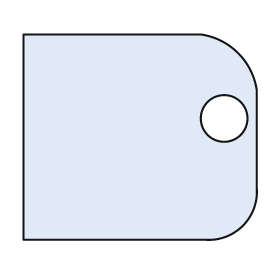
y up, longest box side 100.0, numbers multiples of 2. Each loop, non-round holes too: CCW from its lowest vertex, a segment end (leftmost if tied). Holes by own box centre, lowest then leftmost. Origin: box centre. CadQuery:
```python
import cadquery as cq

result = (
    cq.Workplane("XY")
    .moveTo(-50.0, -44.0)
    .lineTo(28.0, -44.0)
    .threePointArc((44.0, -38.0), (50.0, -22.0))
    .lineTo(50.0, 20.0)
    .threePointArc((42.0, 36.0), (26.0, 44.0))
    .lineTo(-50.0, 44.0)
    .close()
    .moveTo(36.0, 8.0)
    .circle(10.0)
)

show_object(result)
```